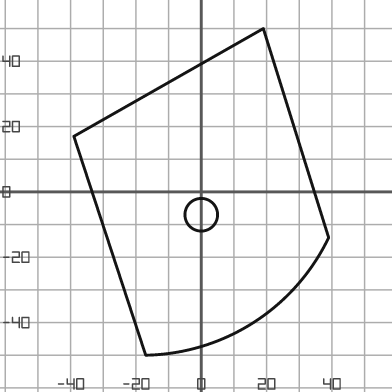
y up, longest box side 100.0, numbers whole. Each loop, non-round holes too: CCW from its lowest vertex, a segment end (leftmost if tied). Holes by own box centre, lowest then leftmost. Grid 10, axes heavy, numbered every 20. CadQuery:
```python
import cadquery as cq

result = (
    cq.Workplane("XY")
    .moveTo(-17.0, -50.0)
    .threePointArc((16.0, -40.0), (39.0, -14.0))
    .lineTo(19.0, 50.0)
    .lineTo(-39.0, 17.0)
    .close()
    .moveTo(0.0, -7.0)
    .circle(5.0)
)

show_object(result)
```